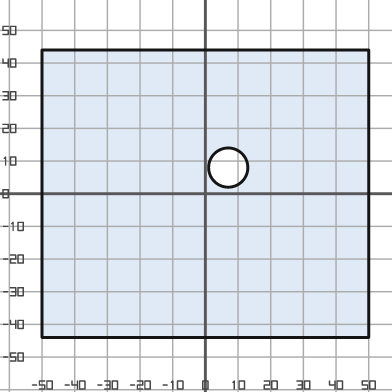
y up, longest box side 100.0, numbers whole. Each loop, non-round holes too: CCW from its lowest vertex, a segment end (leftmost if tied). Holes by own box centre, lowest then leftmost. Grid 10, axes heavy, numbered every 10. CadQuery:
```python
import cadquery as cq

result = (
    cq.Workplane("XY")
    .moveTo(-50.0, -44.0)
    .lineTo(50.0, -44.0)
    .lineTo(50.0, 44.0)
    .lineTo(-50.0, 44.0)
    .close()
    .moveTo(7.0, 8.0)
    .circle(6.0)
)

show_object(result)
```